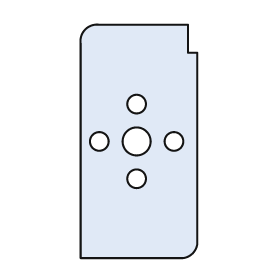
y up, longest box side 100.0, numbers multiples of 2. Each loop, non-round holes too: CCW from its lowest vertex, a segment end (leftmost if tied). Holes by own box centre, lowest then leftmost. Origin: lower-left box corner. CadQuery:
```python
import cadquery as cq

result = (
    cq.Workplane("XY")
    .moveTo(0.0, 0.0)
    .lineTo(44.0, 0.0)
    .threePointArc((48.0, 2.0), (50.0, 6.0))
    .lineTo(50.0, 88.0)
    .lineTo(46.0, 88.0)
    .lineTo(46.0, 100.0)
    .lineTo(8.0, 100.0)
    .threePointArc((2.0, 98.0), (0.0, 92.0))
    .close()
    .moveTo(24.0, 34.0)
    .circle(4.0)
    .moveTo(8.0, 50.0)
    .circle(4.0)
    .moveTo(24.0, 50.0)
    .circle(6.0)
    .moveTo(40.0, 50.0)
    .circle(4.0)
    .moveTo(24.0, 66.0)
    .circle(4.0)
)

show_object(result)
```